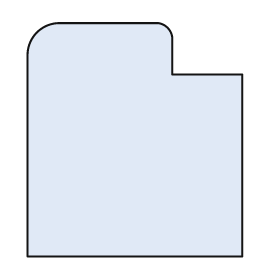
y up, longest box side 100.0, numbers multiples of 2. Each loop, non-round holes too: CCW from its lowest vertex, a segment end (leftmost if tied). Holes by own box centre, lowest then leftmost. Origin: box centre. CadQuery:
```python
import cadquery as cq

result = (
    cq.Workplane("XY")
    .moveTo(-46.0, -50.0)
    .lineTo(46.0, -50.0)
    .lineTo(46.0, 28.0)
    .lineTo(16.0, 28.0)
    .lineTo(16.0, 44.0)
    .threePointArc((14.0, 48.0), (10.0, 50.0))
    .lineTo(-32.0, 50.0)
    .threePointArc((-42.0, 46.0), (-46.0, 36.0))
    .close()
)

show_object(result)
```